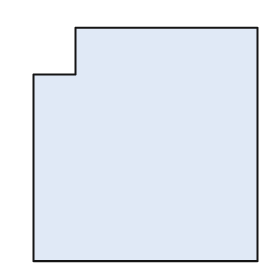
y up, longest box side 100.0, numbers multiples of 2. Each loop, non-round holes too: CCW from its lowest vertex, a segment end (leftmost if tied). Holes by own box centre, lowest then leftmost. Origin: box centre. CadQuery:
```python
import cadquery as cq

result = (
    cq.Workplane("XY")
    .moveTo(-48.0, -50.0)
    .lineTo(48.0, -50.0)
    .lineTo(48.0, 50.0)
    .lineTo(-30.0, 50.0)
    .lineTo(-30.0, 30.0)
    .lineTo(-48.0, 30.0)
    .close()
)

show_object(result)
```